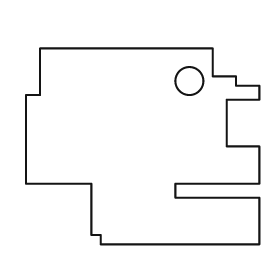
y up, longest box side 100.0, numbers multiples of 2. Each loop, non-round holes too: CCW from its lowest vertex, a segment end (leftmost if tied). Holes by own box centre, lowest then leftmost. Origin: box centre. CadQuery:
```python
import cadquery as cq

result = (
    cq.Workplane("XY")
    .moveTo(-18.0, -42.0)
    .lineTo(50.0, -42.0)
    .lineTo(50.0, -22.0)
    .lineTo(14.0, -22.0)
    .lineTo(14.0, -16.0)
    .lineTo(50.0, -16.0)
    .lineTo(50.0, 0.0)
    .lineTo(36.0, 0.0)
    .lineTo(36.0, 20.0)
    .lineTo(50.0, 20.0)
    .lineTo(50.0, 26.0)
    .lineTo(40.0, 26.0)
    .lineTo(40.0, 30.0)
    .lineTo(30.0, 30.0)
    .lineTo(30.0, 42.0)
    .lineTo(-44.0, 42.0)
    .lineTo(-44.0, 22.0)
    .lineTo(-50.0, 22.0)
    .lineTo(-50.0, -16.0)
    .lineTo(-22.0, -16.0)
    .lineTo(-22.0, -38.0)
    .lineTo(-18.0, -38.0)
    .close()
    .moveTo(20.0, 28.0)
    .circle(6.0)
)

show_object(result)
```